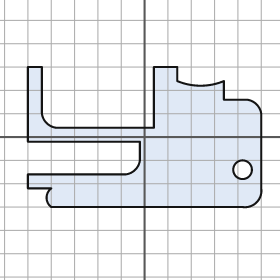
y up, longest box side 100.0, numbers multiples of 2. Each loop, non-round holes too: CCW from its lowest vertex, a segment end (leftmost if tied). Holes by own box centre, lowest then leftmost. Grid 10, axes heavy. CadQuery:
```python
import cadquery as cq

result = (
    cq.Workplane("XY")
    .moveTo(-40.0, -30.0)
    .lineTo(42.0, -30.0)
    .threePointArc((48.0, -28.0), (50.0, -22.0))
    .lineTo(50.0, 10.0)
    .threePointArc((48.0, 14.0), (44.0, 16.0))
    .lineTo(34.0, 16.0)
    .lineTo(34.0, 24.0)
    .threePointArc((24.0, 22.0), (14.0, 24.0))
    .lineTo(14.0, 30.0)
    .lineTo(4.0, 30.0)
    .lineTo(4.0, 4.0)
    .lineTo(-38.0, 4.0)
    .threePointArc((-42.0, 6.0), (-44.0, 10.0))
    .lineTo(-44.0, 30.0)
    .lineTo(-50.0, 30.0)
    .lineTo(-50.0, -2.0)
    .lineTo(-2.0, -2.0)
    .lineTo(-2.0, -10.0)
    .threePointArc((-4.0, -14.0), (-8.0, -16.0))
    .lineTo(-50.0, -16.0)
    .lineTo(-50.0, -22.0)
    .lineTo(-40.0, -22.0)
    .threePointArc((-42.0, -26.0), (-40.0, -30.0))
    .close()
    .moveTo(42.0, -14.0)
    .circle(4.0)
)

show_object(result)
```